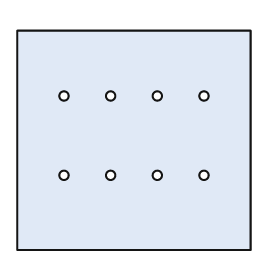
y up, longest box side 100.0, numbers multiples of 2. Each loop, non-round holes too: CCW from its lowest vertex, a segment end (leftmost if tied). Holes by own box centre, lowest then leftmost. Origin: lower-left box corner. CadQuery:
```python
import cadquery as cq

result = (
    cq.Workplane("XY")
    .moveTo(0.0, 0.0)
    .lineTo(100.0, 0.0)
    .lineTo(100.0, 94.0)
    .lineTo(0.0, 94.0)
    .close()
    .moveTo(20.0, 32.0)
    .circle(2.0)
    .moveTo(40.0, 32.0)
    .circle(2.0)
    .moveTo(60.0, 32.0)
    .circle(2.0)
    .moveTo(80.0, 32.0)
    .circle(2.0)
    .moveTo(20.0, 66.0)
    .circle(2.0)
    .moveTo(40.0, 66.0)
    .circle(2.0)
    .moveTo(60.0, 66.0)
    .circle(2.0)
    .moveTo(80.0, 66.0)
    .circle(2.0)
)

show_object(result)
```